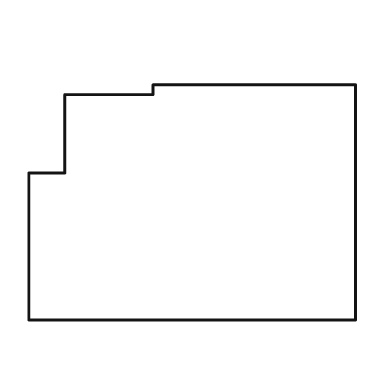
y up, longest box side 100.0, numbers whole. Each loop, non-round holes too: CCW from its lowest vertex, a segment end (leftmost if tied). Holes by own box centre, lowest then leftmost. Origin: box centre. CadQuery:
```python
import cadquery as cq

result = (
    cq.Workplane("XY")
    .moveTo(-50.0, -36.0)
    .lineTo(50.0, -36.0)
    .lineTo(50.0, 36.0)
    .lineTo(-12.0, 36.0)
    .lineTo(-12.0, 33.0)
    .lineTo(-39.0, 33.0)
    .lineTo(-39.0, 9.0)
    .lineTo(-50.0, 9.0)
    .close()
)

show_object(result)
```